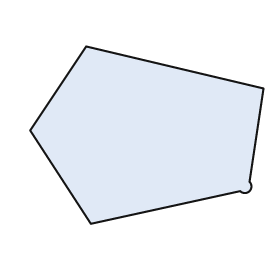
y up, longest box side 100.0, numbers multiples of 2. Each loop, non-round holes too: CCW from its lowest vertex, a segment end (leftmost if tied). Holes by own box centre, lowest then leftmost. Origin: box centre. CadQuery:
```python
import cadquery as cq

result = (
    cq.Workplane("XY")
    .moveTo(-24.0, -38.0)
    .lineTo(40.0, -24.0)
    .threePointArc((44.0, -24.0), (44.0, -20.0))
    .lineTo(50.0, 20.0)
    .lineTo(-26.0, 38.0)
    .lineTo(-50.0, 2.0)
    .close()
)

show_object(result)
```